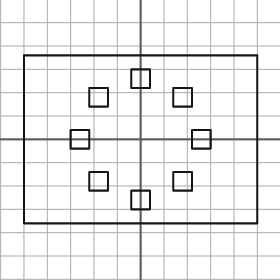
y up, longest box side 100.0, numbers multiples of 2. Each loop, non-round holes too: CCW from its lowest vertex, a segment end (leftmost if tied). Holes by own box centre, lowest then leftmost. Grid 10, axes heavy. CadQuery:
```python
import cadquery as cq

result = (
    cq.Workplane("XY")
    .moveTo(-50.0, -36.0)
    .lineTo(50.0, -36.0)
    .lineTo(50.0, 36.0)
    .lineTo(-50.0, 36.0)
    .close()
    .moveTo(-4.0, -30.0)
    .lineTo(4.0, -30.0)
    .lineTo(4.0, -22.0)
    .lineTo(-4.0, -22.0)
    .close()
    .moveTo(-22.0, -22.0)
    .lineTo(-14.0, -22.0)
    .lineTo(-14.0, -14.0)
    .lineTo(-22.0, -14.0)
    .close()
    .moveTo(14.0, -22.0)
    .lineTo(22.0, -22.0)
    .lineTo(22.0, -14.0)
    .lineTo(14.0, -14.0)
    .close()
    .moveTo(-30.0, -4.0)
    .lineTo(-22.0, -4.0)
    .lineTo(-22.0, 4.0)
    .lineTo(-30.0, 4.0)
    .close()
    .moveTo(22.0, -4.0)
    .lineTo(30.0, -4.0)
    .lineTo(30.0, 4.0)
    .lineTo(22.0, 4.0)
    .close()
    .moveTo(-22.0, 14.0)
    .lineTo(-14.0, 14.0)
    .lineTo(-14.0, 22.0)
    .lineTo(-22.0, 22.0)
    .close()
    .moveTo(14.0, 14.0)
    .lineTo(22.0, 14.0)
    .lineTo(22.0, 22.0)
    .lineTo(14.0, 22.0)
    .close()
    .moveTo(-4.0, 22.0)
    .lineTo(4.0, 22.0)
    .lineTo(4.0, 30.0)
    .lineTo(-4.0, 30.0)
    .close()
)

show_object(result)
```